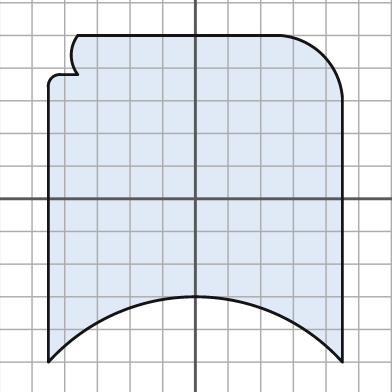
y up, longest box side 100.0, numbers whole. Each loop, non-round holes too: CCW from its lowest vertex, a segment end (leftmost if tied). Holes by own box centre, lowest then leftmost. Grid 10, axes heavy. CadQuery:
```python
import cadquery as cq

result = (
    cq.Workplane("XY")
    .moveTo(-45.0, -50.0)
    .threePointArc((0.0, -30.0), (45.0, -50.0))
    .lineTo(45.0, 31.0)
    .threePointArc((39.0, 44.0), (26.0, 50.0))
    .lineTo(-36.0, 50.0)
    .threePointArc((-38.0, 44.0), (-36.0, 38.0))
    .lineTo(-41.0, 38.0)
    .threePointArc((-44.0, 37.0), (-45.0, 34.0))
    .close()
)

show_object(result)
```